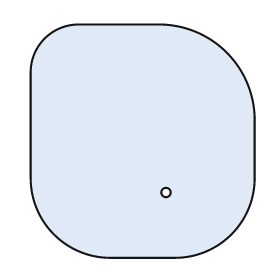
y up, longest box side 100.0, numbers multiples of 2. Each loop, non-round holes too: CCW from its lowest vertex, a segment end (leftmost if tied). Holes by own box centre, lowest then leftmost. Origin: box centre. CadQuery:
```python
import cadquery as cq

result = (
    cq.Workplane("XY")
    .moveTo(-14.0, -50.0)
    .lineTo(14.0, -50.0)
    .threePointArc((38.0, -40.0), (48.0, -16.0))
    .lineTo(48.0, 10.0)
    .threePointArc((36.0, 38.0), (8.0, 50.0))
    .lineTo(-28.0, 50.0)
    .threePointArc((-42.0, 44.0), (-48.0, 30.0))
    .lineTo(-48.0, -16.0)
    .threePointArc((-38.0, -40.0), (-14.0, -50.0))
    .close()
    .moveTo(10.0, -22.0)
    .circle(2.0)
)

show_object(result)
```